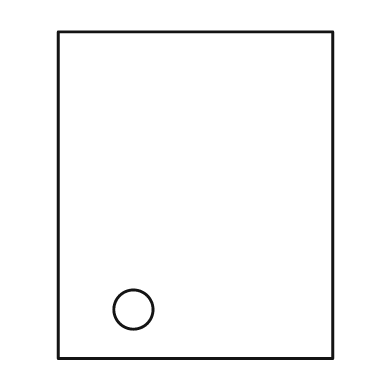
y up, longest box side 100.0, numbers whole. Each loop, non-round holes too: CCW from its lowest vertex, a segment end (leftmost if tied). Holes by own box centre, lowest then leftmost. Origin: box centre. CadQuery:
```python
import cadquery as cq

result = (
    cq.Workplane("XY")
    .moveTo(-42.0, -50.0)
    .lineTo(42.0, -50.0)
    .lineTo(42.0, 50.0)
    .lineTo(-42.0, 50.0)
    .close()
    .moveTo(-19.0, -35.0)
    .circle(6.0)
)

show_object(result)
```